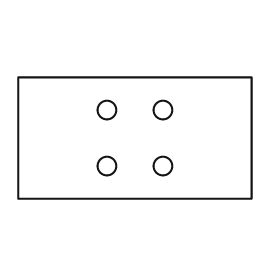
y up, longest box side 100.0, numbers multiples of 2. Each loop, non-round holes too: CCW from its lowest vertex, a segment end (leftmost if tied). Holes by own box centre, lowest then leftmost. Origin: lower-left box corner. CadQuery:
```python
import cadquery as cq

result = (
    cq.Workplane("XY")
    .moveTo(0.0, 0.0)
    .lineTo(100.0, 0.0)
    .lineTo(100.0, 52.0)
    .lineTo(0.0, 52.0)
    .close()
    .moveTo(38.0, 14.0)
    .circle(4.0)
    .moveTo(62.0, 14.0)
    .circle(4.0)
    .moveTo(38.0, 38.0)
    .circle(4.0)
    .moveTo(62.0, 38.0)
    .circle(4.0)
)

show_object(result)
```